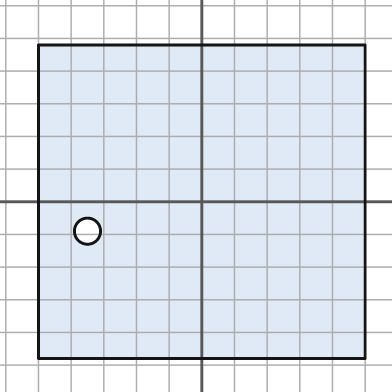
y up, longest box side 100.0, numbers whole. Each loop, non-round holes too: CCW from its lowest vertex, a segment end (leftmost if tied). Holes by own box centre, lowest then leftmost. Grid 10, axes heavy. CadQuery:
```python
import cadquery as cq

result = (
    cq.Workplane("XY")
    .moveTo(-50.0, -48.0)
    .lineTo(50.0, -48.0)
    .lineTo(50.0, 48.0)
    .lineTo(-50.0, 48.0)
    .close()
    .moveTo(-35.0, -9.0)
    .circle(4.0)
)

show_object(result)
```